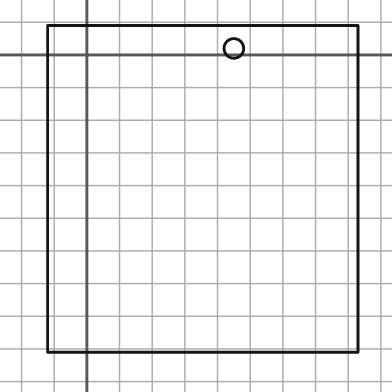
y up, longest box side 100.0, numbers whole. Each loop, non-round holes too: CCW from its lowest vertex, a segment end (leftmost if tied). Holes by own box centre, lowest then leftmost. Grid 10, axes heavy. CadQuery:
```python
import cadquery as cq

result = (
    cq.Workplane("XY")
    .moveTo(-12.0, -91.0)
    .lineTo(83.0, -91.0)
    .lineTo(83.0, 9.0)
    .lineTo(-12.0, 9.0)
    .close()
    .moveTo(45.0, 2.0)
    .circle(3.0)
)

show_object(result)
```